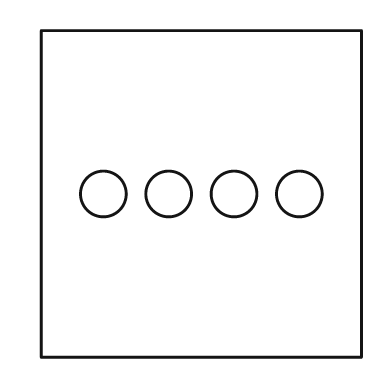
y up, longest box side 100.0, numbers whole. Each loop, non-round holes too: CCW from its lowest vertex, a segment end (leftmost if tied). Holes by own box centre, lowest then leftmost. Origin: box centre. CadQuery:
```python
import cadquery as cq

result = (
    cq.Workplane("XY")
    .moveTo(-49.0, -50.0)
    .lineTo(49.0, -50.0)
    .lineTo(49.0, 50.0)
    .lineTo(-49.0, 50.0)
    .close()
    .moveTo(-30.0, 0.0)
    .circle(7.0)
    .moveTo(-10.0, 0.0)
    .circle(7.0)
    .moveTo(10.0, 0.0)
    .circle(7.0)
    .moveTo(30.0, 0.0)
    .circle(7.0)
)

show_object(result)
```